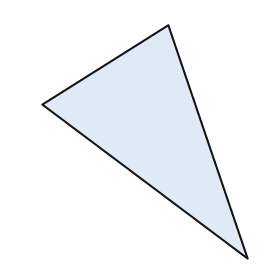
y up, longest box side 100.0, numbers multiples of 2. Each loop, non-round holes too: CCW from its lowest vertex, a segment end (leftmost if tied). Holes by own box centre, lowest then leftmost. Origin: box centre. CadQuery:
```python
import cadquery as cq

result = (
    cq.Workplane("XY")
    .moveTo(44.0, -50.0)
    .lineTo(10.0, 50.0)
    .lineTo(-44.0, 16.0)
    .close()
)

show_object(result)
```